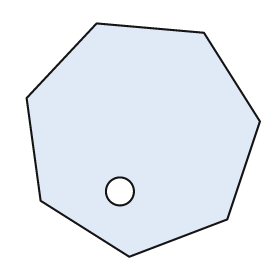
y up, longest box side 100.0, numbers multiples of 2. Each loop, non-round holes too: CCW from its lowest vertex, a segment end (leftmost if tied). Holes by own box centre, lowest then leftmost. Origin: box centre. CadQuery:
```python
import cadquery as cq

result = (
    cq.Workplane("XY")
    .moveTo(-6.0, -50.0)
    .lineTo(36.0, -34.0)
    .lineTo(50.0, 8.0)
    .lineTo(26.0, 46.0)
    .lineTo(-20.0, 50.0)
    .lineTo(-50.0, 18.0)
    .lineTo(-44.0, -26.0)
    .close()
    .moveTo(-10.0, -22.0)
    .circle(6.0)
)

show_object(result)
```